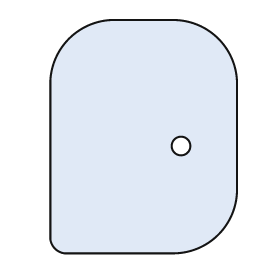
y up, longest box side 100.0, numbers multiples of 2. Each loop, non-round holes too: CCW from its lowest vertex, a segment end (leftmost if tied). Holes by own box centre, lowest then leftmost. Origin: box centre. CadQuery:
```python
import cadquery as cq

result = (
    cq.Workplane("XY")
    .moveTo(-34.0, -50.0)
    .lineTo(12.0, -50.0)
    .threePointArc((32.0, -42.0), (40.0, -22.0))
    .lineTo(40.0, 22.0)
    .threePointArc((32.0, 42.0), (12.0, 50.0))
    .lineTo(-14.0, 50.0)
    .threePointArc((-32.0, 42.0), (-40.0, 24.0))
    .lineTo(-40.0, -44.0)
    .threePointArc((-38.0, -48.0), (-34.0, -50.0))
    .close()
    .moveTo(16.0, -4.0)
    .circle(4.0)
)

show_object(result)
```